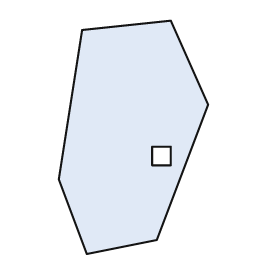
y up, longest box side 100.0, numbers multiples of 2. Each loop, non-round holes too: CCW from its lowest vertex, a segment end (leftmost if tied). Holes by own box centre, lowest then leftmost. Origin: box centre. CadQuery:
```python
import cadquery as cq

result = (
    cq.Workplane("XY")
    .moveTo(-20.0, -50.0)
    .lineTo(10.0, -44.0)
    .lineTo(32.0, 14.0)
    .lineTo(16.0, 50.0)
    .lineTo(-22.0, 46.0)
    .lineTo(-32.0, -18.0)
    .close()
    .moveTo(8.0, -12.0)
    .lineTo(16.0, -12.0)
    .lineTo(16.0, -4.0)
    .lineTo(8.0, -4.0)
    .close()
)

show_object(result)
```